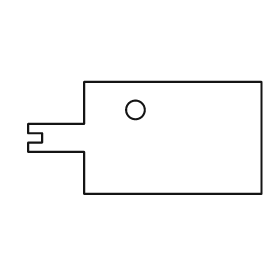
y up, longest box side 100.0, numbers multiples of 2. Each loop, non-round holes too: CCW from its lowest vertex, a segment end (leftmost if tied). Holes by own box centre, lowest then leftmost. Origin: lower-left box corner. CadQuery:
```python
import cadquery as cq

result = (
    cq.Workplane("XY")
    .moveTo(24.0, 0.0)
    .lineTo(100.0, 0.0)
    .lineTo(100.0, 48.0)
    .lineTo(24.0, 48.0)
    .lineTo(24.0, 30.0)
    .lineTo(0.0, 30.0)
    .lineTo(0.0, 26.0)
    .lineTo(6.0, 26.0)
    .lineTo(6.0, 22.0)
    .lineTo(0.0, 22.0)
    .lineTo(0.0, 18.0)
    .lineTo(24.0, 18.0)
    .close()
    .moveTo(46.0, 36.0)
    .circle(4.0)
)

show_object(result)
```